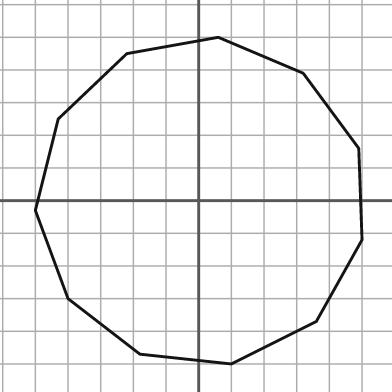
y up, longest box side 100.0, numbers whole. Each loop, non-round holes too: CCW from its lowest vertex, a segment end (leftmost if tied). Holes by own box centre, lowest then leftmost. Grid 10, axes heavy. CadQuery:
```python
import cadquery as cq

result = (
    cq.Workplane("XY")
    .moveTo(10.0, -50.0)
    .lineTo(36.0, -37.0)
    .lineTo(50.0, -12.0)
    .lineTo(49.0, 16.0)
    .lineTo(32.0, 39.0)
    .lineTo(6.0, 50.0)
    .lineTo(-22.0, 45.0)
    .lineTo(-43.0, 25.0)
    .lineTo(-50.0, -3.0)
    .lineTo(-40.0, -30.0)
    .lineTo(-18.0, -47.0)
    .close()
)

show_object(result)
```